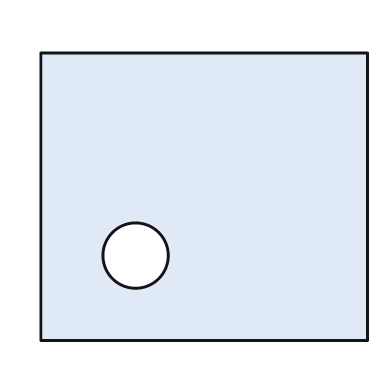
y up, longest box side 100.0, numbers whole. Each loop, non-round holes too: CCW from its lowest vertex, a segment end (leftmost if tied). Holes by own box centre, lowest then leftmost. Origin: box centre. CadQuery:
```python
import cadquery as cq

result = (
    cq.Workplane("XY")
    .moveTo(-50.0, -44.0)
    .lineTo(50.0, -44.0)
    .lineTo(50.0, 44.0)
    .lineTo(-50.0, 44.0)
    .close()
    .moveTo(-21.0, -18.0)
    .circle(10.0)
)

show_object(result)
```